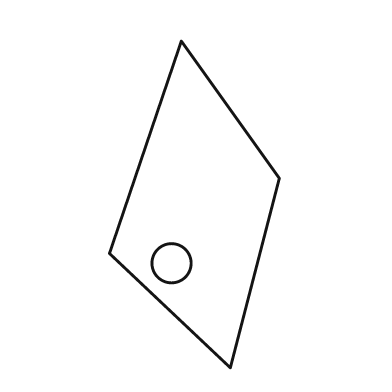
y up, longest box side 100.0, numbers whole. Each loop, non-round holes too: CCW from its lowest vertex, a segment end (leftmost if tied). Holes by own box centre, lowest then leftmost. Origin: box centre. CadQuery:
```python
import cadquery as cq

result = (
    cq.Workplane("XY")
    .moveTo(11.0, -50.0)
    .lineTo(26.0, 8.0)
    .lineTo(-4.0, 50.0)
    .lineTo(-26.0, -15.0)
    .close()
    .moveTo(-7.0, -18.0)
    .circle(6.0)
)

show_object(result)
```